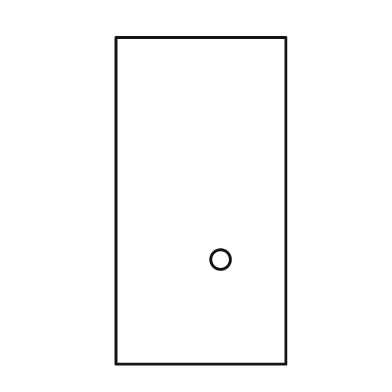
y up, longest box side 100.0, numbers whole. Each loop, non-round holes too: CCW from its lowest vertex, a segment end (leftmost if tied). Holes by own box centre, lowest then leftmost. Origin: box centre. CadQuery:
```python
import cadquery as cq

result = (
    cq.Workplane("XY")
    .moveTo(-26.0, -50.0)
    .lineTo(26.0, -50.0)
    .lineTo(26.0, 50.0)
    .lineTo(-26.0, 50.0)
    .close()
    .moveTo(6.0, -18.0)
    .circle(3.0)
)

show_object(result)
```